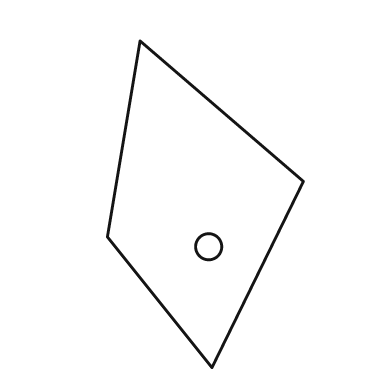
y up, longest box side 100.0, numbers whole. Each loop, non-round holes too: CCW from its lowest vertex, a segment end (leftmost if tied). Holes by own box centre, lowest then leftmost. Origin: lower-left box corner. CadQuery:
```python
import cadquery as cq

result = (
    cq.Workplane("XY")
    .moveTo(32.0, 0.0)
    .lineTo(60.0, 57.0)
    .lineTo(10.0, 100.0)
    .lineTo(0.0, 40.0)
    .close()
    .moveTo(31.0, 37.0)
    .circle(4.0)
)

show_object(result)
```